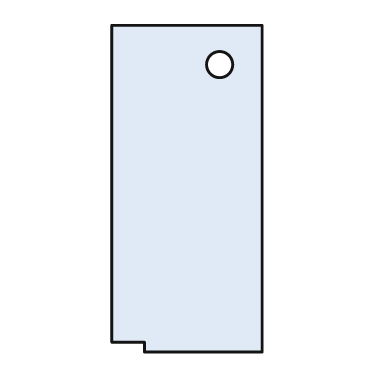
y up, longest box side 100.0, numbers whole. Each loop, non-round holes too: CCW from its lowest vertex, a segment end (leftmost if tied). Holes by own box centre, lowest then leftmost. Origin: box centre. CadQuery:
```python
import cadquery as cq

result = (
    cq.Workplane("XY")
    .moveTo(-13.0, -50.0)
    .lineTo(23.0, -50.0)
    .lineTo(23.0, 50.0)
    .lineTo(-23.0, 50.0)
    .lineTo(-23.0, -47.0)
    .lineTo(-13.0, -47.0)
    .close()
    .moveTo(10.0, 38.0)
    .circle(4.0)
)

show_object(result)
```